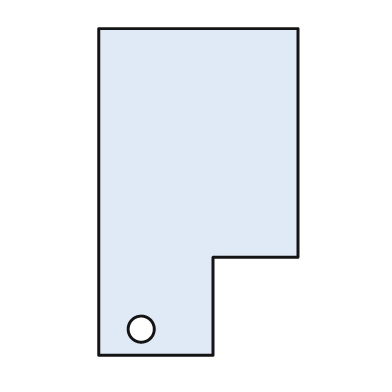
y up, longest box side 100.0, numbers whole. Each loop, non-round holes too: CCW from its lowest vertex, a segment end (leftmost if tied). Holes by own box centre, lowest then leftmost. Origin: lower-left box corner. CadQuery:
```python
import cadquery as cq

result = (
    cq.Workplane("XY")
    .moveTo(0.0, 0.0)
    .lineTo(35.0, 0.0)
    .lineTo(35.0, 30.0)
    .lineTo(61.0, 30.0)
    .lineTo(61.0, 100.0)
    .lineTo(0.0, 100.0)
    .close()
    .moveTo(13.0, 8.0)
    .circle(4.0)
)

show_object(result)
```